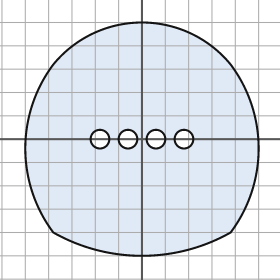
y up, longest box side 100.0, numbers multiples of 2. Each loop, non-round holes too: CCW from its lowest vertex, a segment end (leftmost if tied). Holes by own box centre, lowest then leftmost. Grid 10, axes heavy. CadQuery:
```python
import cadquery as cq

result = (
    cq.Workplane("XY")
    .moveTo(-38.0, -40.0)
    .threePointArc((0.0, -50.0), (38.0, -40.0))
    .threePointArc((50.0, -4.0), (38.0, 32.0))
    .threePointArc((0.0, 50.0), (-38.0, 32.0))
    .threePointArc((-50.0, -4.0), (-38.0, -40.0))
    .close()
    .moveTo(-18.0, 0.0)
    .circle(4.0)
    .moveTo(-6.0, 0.0)
    .circle(4.0)
    .moveTo(6.0, 0.0)
    .circle(4.0)
    .moveTo(18.0, 0.0)
    .circle(4.0)
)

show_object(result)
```